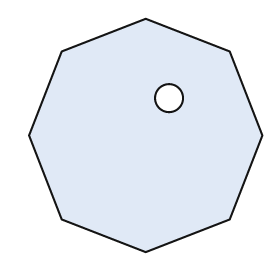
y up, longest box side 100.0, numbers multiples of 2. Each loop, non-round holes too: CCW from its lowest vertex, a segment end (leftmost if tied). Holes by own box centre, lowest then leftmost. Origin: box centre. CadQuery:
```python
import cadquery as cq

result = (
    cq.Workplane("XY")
    .moveTo(0.0, -50.0)
    .lineTo(36.0, -36.0)
    .lineTo(50.0, 0.0)
    .lineTo(36.0, 36.0)
    .lineTo(0.0, 50.0)
    .lineTo(-36.0, 36.0)
    .lineTo(-50.0, 0.0)
    .lineTo(-36.0, -36.0)
    .close()
    .moveTo(10.0, 16.0)
    .circle(6.0)
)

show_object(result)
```